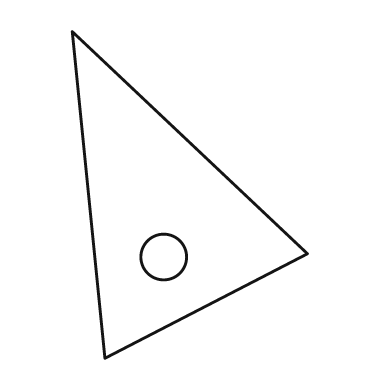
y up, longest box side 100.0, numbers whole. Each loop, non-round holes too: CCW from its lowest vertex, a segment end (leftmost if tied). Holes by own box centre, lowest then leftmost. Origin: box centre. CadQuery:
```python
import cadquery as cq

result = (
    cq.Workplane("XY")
    .moveTo(-26.0, -50.0)
    .lineTo(36.0, -18.0)
    .lineTo(-36.0, 50.0)
    .close()
    .moveTo(-8.0, -19.0)
    .circle(7.0)
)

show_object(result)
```